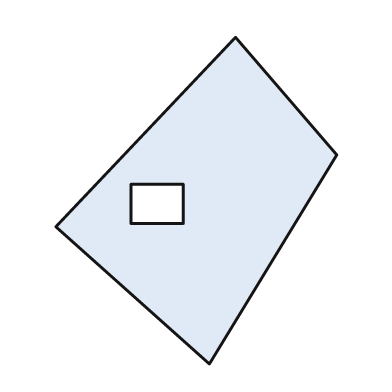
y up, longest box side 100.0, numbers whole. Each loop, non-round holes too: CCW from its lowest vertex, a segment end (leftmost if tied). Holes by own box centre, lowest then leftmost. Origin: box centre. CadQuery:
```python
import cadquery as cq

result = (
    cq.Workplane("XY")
    .moveTo(4.0, -50.0)
    .lineTo(43.0, 14.0)
    .lineTo(12.0, 50.0)
    .lineTo(-43.0, -8.0)
    .close()
    .moveTo(-20.0, -7.0)
    .lineTo(-4.0, -7.0)
    .lineTo(-4.0, 5.0)
    .lineTo(-20.0, 5.0)
    .close()
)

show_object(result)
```